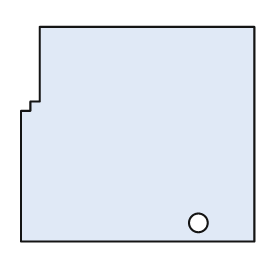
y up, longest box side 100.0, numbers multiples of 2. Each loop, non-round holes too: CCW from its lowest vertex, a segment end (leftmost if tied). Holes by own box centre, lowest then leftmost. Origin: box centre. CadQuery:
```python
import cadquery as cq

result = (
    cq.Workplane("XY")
    .moveTo(-50.0, -46.0)
    .lineTo(50.0, -46.0)
    .lineTo(50.0, 46.0)
    .lineTo(-42.0, 46.0)
    .lineTo(-42.0, 14.0)
    .lineTo(-46.0, 14.0)
    .lineTo(-46.0, 10.0)
    .lineTo(-50.0, 10.0)
    .close()
    .moveTo(26.0, -38.0)
    .circle(4.0)
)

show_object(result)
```